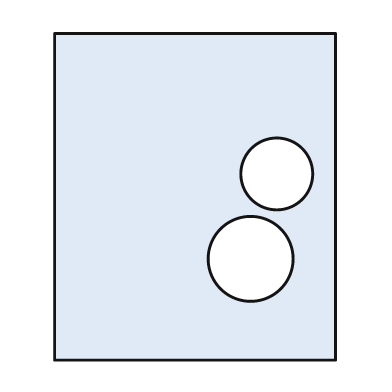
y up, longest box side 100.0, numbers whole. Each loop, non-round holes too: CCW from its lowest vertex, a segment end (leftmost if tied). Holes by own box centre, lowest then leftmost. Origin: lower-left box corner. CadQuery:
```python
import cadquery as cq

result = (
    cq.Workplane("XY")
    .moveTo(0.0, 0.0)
    .lineTo(86.0, 0.0)
    .lineTo(86.0, 100.0)
    .lineTo(0.0, 100.0)
    .close()
    .moveTo(60.0, 31.0)
    .circle(13.0)
    .moveTo(68.0, 57.0)
    .circle(11.0)
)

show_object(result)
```